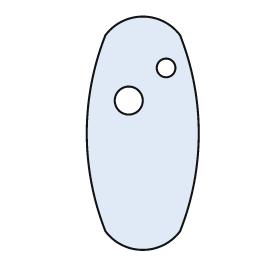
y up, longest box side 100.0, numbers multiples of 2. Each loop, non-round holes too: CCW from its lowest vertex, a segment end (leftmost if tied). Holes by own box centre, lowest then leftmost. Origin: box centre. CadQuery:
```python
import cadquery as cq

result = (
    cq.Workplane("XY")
    .moveTo(-16.0, -42.0)
    .threePointArc((0.0, -50.0), (16.0, -42.0))
    .threePointArc((24.0, 0.0), (16.0, 42.0))
    .threePointArc((0.0, 50.0), (-16.0, 42.0))
    .threePointArc((-24.0, 0.0), (-16.0, -42.0))
    .close()
    .moveTo(-6.0, 14.0)
    .circle(6.0)
    .moveTo(10.0, 28.0)
    .circle(4.0)
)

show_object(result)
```